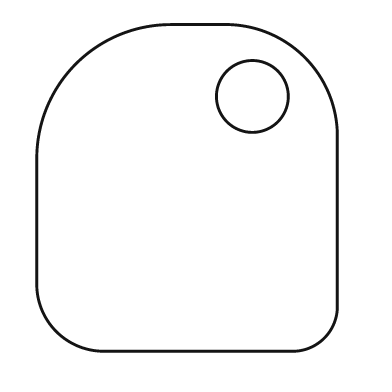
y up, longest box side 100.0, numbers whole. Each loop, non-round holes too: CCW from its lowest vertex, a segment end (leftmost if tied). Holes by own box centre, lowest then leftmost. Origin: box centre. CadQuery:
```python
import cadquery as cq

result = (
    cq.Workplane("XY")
    .moveTo(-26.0, -50.0)
    .lineTo(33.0, -50.0)
    .threePointArc((42.0, -46.0), (46.0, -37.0))
    .lineTo(46.0, 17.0)
    .threePointArc((36.0, 40.0), (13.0, 50.0))
    .lineTo(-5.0, 50.0)
    .threePointArc((-34.0, 38.0), (-46.0, 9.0))
    .lineTo(-46.0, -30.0)
    .threePointArc((-40.0, -44.0), (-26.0, -50.0))
    .close()
    .moveTo(20.0, 28.0)
    .circle(11.0)
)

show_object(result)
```